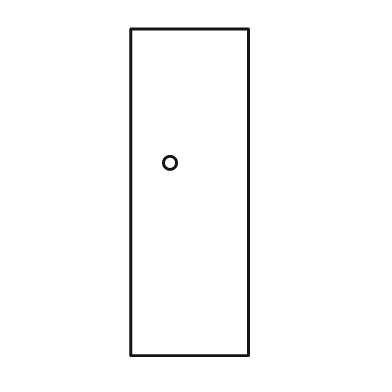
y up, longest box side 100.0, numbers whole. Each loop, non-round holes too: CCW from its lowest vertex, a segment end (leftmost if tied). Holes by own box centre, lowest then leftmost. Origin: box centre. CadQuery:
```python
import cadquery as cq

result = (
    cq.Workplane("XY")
    .moveTo(-18.0, -50.0)
    .lineTo(18.0, -50.0)
    .lineTo(18.0, 50.0)
    .lineTo(-18.0, 50.0)
    .close()
    .moveTo(-6.0, 9.0)
    .circle(2.0)
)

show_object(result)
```